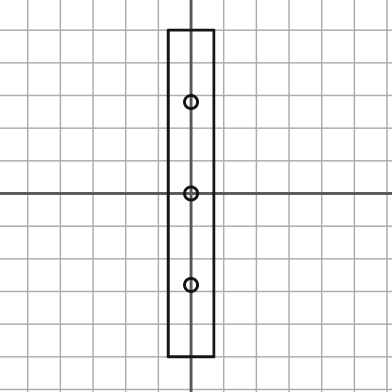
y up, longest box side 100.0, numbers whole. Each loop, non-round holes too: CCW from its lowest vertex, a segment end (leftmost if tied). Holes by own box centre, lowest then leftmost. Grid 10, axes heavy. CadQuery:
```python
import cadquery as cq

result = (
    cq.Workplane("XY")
    .moveTo(-7.0, -50.0)
    .lineTo(7.0, -50.0)
    .lineTo(7.0, 50.0)
    .lineTo(-7.0, 50.0)
    .close()
    .moveTo(0.0, -28.0)
    .circle(2.0)
    .moveTo(0.0, 0.0)
    .circle(2.0)
    .moveTo(0.0, 28.0)
    .circle(2.0)
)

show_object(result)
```